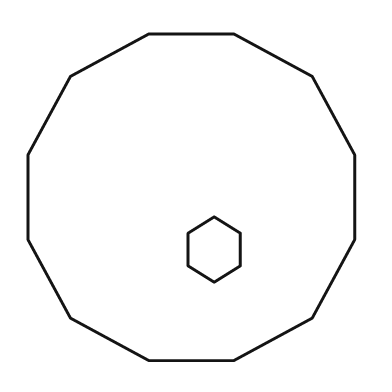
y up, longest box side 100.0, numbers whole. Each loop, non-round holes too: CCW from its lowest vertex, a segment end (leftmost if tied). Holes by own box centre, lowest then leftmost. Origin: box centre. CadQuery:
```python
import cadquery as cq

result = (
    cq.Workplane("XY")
    .moveTo(-13.0, -50.0)
    .lineTo(13.0, -50.0)
    .lineTo(37.0, -37.0)
    .lineTo(50.0, -13.0)
    .lineTo(50.0, 13.0)
    .lineTo(37.0, 37.0)
    .lineTo(13.0, 50.0)
    .lineTo(-13.0, 50.0)
    .lineTo(-37.0, 37.0)
    .lineTo(-50.0, 13.0)
    .lineTo(-50.0, -13.0)
    .lineTo(-37.0, -37.0)
    .close()
    .moveTo(7.0, -26.0)
    .lineTo(15.0, -21.0)
    .lineTo(15.0, -11.0)
    .lineTo(7.0, -6.0)
    .lineTo(-1.0, -11.0)
    .lineTo(-1.0, -21.0)
    .close()
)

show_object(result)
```